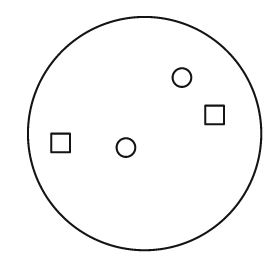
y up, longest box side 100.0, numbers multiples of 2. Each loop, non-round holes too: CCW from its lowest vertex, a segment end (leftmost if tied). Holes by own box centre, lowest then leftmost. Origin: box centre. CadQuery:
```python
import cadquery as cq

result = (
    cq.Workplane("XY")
    .moveTo(0.0, 0.0)
    .circle(50.0)
    .moveTo(-8.0, -6.0)
    .circle(4.0)
    .moveTo(-40.0, -8.0)
    .lineTo(-32.0, -8.0)
    .lineTo(-32.0, 0.0)
    .lineTo(-40.0, 0.0)
    .close()
    .moveTo(26.0, 4.0)
    .lineTo(34.0, 4.0)
    .lineTo(34.0, 12.0)
    .lineTo(26.0, 12.0)
    .close()
    .moveTo(16.0, 24.0)
    .circle(4.0)
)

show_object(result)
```